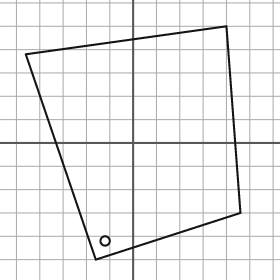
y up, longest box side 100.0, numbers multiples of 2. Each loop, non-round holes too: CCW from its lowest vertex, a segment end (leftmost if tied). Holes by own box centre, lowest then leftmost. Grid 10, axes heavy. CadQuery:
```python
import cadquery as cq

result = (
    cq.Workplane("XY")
    .moveTo(-16.0, -50.0)
    .lineTo(46.0, -30.0)
    .lineTo(40.0, 50.0)
    .lineTo(-46.0, 38.0)
    .close()
    .moveTo(-12.0, -42.0)
    .circle(2.0)
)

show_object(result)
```